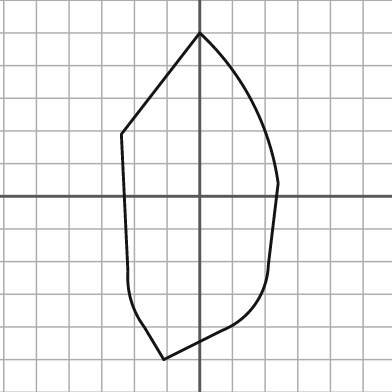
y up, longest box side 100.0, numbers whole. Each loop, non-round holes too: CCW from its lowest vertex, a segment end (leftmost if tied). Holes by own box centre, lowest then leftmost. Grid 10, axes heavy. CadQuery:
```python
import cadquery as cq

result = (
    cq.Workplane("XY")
    .moveTo(-11.0, -50.0)
    .lineTo(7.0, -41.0)
    .threePointArc((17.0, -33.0), (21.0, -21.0))
    .lineTo(24.0, 4.0)
    .threePointArc((16.0, 29.0), (0.0, 50.0))
    .lineTo(-24.0, 19.0)
    .lineTo(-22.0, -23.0)
    .threePointArc((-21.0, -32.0), (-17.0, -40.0))
    .close()
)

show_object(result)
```